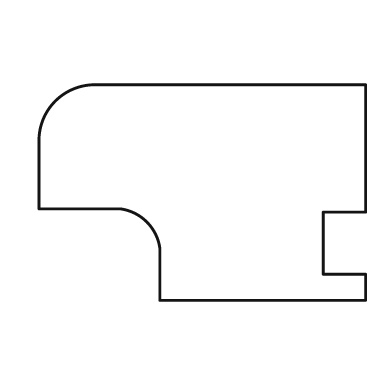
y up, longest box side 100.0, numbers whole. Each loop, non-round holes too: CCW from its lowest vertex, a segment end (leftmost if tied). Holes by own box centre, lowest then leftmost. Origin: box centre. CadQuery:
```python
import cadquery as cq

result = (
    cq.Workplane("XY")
    .moveTo(-13.0, -33.0)
    .lineTo(50.0, -33.0)
    .lineTo(50.0, -25.0)
    .lineTo(37.0, -25.0)
    .lineTo(37.0, -6.0)
    .lineTo(50.0, -6.0)
    .lineTo(50.0, 33.0)
    .lineTo(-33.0, 33.0)
    .threePointArc((-45.0, 28.0), (-50.0, 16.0))
    .lineTo(-50.0, -5.0)
    .lineTo(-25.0, -5.0)
    .threePointArc((-17.0, -9.0), (-13.0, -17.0))
    .close()
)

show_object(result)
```